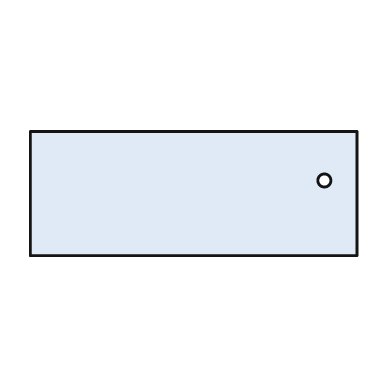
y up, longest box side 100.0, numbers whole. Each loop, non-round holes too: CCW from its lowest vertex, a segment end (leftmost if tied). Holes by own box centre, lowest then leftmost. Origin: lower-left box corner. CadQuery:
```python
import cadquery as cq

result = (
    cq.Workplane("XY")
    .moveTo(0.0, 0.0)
    .lineTo(100.0, 0.0)
    .lineTo(100.0, 38.0)
    .lineTo(0.0, 38.0)
    .close()
    .moveTo(90.0, 23.0)
    .circle(2.0)
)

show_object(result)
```